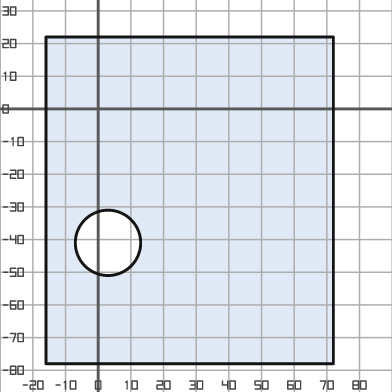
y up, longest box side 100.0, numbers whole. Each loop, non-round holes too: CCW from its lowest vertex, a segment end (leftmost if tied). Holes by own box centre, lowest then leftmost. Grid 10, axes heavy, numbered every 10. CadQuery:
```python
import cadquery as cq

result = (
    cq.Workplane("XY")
    .moveTo(-16.0, -78.0)
    .lineTo(72.0, -78.0)
    .lineTo(72.0, 22.0)
    .lineTo(-16.0, 22.0)
    .close()
    .moveTo(3.0, -41.0)
    .circle(10.0)
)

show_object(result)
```